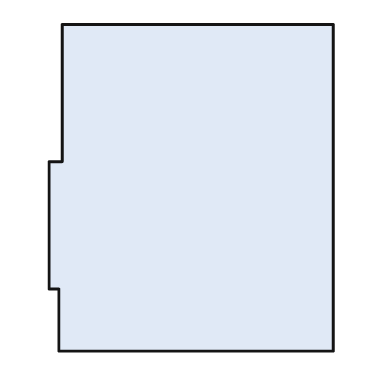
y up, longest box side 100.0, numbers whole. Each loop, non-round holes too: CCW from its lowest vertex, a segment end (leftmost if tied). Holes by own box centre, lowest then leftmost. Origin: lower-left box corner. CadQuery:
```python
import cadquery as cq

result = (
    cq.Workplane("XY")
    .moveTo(3.0, 0.0)
    .lineTo(87.0, 0.0)
    .lineTo(87.0, 100.0)
    .lineTo(4.0, 100.0)
    .lineTo(4.0, 58.0)
    .lineTo(0.0, 58.0)
    .lineTo(0.0, 19.0)
    .lineTo(3.0, 19.0)
    .close()
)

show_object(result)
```